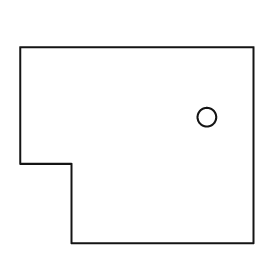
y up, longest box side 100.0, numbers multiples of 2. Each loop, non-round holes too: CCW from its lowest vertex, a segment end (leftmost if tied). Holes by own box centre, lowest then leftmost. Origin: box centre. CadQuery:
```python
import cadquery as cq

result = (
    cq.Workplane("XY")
    .moveTo(-28.0, -42.0)
    .lineTo(50.0, -42.0)
    .lineTo(50.0, 42.0)
    .lineTo(-50.0, 42.0)
    .lineTo(-50.0, -8.0)
    .lineTo(-28.0, -8.0)
    .close()
    .moveTo(30.0, 12.0)
    .circle(4.0)
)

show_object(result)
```